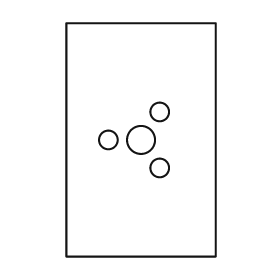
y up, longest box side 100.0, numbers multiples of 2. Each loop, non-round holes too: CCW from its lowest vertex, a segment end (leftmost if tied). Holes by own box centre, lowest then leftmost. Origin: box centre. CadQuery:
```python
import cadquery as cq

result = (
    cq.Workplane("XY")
    .moveTo(-32.0, -50.0)
    .lineTo(32.0, -50.0)
    .lineTo(32.0, 50.0)
    .lineTo(-32.0, 50.0)
    .close()
    .moveTo(8.0, -12.0)
    .circle(4.0)
    .moveTo(-14.0, 0.0)
    .circle(4.0)
    .moveTo(0.0, 0.0)
    .circle(6.0)
    .moveTo(8.0, 12.0)
    .circle(4.0)
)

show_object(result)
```